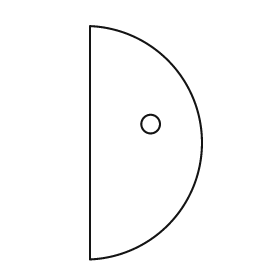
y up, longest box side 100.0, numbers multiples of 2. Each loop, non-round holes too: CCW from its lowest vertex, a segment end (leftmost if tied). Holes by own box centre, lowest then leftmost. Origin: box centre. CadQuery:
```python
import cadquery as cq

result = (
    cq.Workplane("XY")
    .moveTo(-24.0, -50.0)
    .threePointArc((24.0, 0.0), (-24.0, 50.0))
    .close()
    .moveTo(2.0, 8.0)
    .circle(4.0)
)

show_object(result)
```